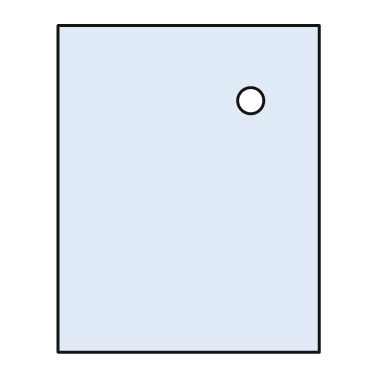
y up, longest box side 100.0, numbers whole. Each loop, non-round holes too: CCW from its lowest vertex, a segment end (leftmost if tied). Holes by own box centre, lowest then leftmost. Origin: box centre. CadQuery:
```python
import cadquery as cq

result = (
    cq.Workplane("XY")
    .moveTo(-40.0, -50.0)
    .lineTo(40.0, -50.0)
    .lineTo(40.0, 50.0)
    .lineTo(-40.0, 50.0)
    .close()
    .moveTo(19.0, 27.0)
    .circle(4.0)
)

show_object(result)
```